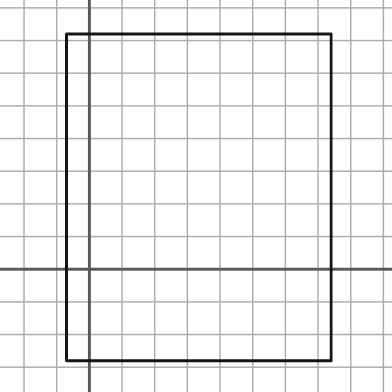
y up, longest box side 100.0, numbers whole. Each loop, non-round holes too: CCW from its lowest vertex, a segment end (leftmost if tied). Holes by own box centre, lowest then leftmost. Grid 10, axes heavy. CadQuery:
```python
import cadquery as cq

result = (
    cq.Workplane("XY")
    .moveTo(-7.0, -28.0)
    .lineTo(74.0, -28.0)
    .lineTo(74.0, 72.0)
    .lineTo(-7.0, 72.0)
    .close()
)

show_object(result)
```